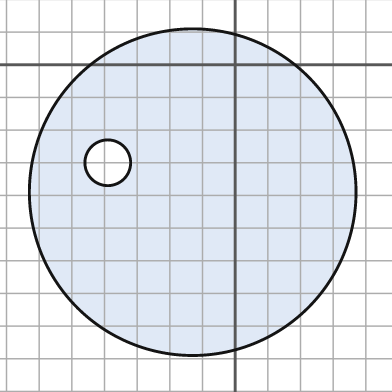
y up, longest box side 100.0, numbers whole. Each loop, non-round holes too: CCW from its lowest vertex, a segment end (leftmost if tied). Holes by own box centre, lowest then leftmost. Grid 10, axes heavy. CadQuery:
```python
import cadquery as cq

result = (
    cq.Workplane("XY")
    .moveTo(-13.0, -39.0)
    .circle(50.0)
    .moveTo(-39.0, -30.0)
    .circle(7.0)
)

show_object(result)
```